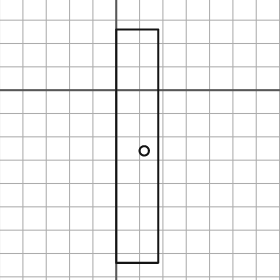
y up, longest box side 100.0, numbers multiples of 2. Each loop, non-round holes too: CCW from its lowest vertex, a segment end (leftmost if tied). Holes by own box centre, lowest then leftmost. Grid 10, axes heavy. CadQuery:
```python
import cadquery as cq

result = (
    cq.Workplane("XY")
    .moveTo(0.0, -74.0)
    .lineTo(18.0, -74.0)
    .lineTo(18.0, 26.0)
    .lineTo(0.0, 26.0)
    .close()
    .moveTo(12.0, -26.0)
    .circle(2.0)
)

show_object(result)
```